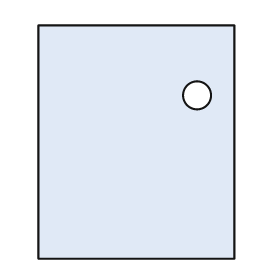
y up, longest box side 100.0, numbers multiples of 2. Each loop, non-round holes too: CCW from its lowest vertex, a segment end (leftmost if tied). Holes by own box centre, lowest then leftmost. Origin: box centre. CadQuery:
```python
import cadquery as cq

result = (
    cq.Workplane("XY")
    .moveTo(-42.0, -50.0)
    .lineTo(42.0, -50.0)
    .lineTo(42.0, 50.0)
    .lineTo(-42.0, 50.0)
    .close()
    .moveTo(26.0, 20.0)
    .circle(6.0)
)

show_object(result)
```